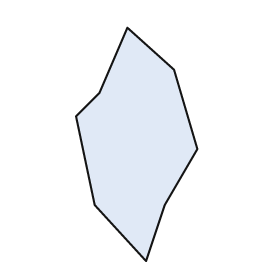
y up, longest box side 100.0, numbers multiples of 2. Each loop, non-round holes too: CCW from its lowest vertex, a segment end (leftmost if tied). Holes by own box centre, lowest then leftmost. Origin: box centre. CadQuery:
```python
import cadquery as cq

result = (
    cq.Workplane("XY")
    .moveTo(4.0, -50.0)
    .lineTo(12.0, -26.0)
    .lineTo(26.0, -2.0)
    .lineTo(16.0, 32.0)
    .lineTo(-4.0, 50.0)
    .lineTo(-16.0, 22.0)
    .lineTo(-26.0, 12.0)
    .lineTo(-18.0, -26.0)
    .close()
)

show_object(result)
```